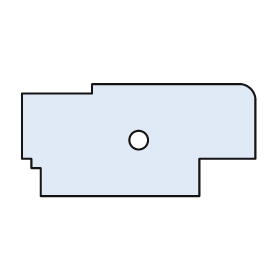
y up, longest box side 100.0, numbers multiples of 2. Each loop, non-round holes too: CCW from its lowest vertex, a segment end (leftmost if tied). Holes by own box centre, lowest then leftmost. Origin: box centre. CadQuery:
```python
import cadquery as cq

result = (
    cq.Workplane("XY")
    .moveTo(-42.0, -24.0)
    .lineTo(26.0, -24.0)
    .lineTo(26.0, -8.0)
    .lineTo(50.0, -8.0)
    .lineTo(50.0, 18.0)
    .threePointArc((48.0, 22.0), (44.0, 24.0))
    .lineTo(-20.0, 24.0)
    .lineTo(-20.0, 20.0)
    .lineTo(-50.0, 20.0)
    .lineTo(-50.0, -8.0)
    .lineTo(-46.0, -8.0)
    .lineTo(-46.0, -12.0)
    .lineTo(-42.0, -12.0)
    .close()
    .moveTo(0.0, 0.0)
    .circle(4.0)
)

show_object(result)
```